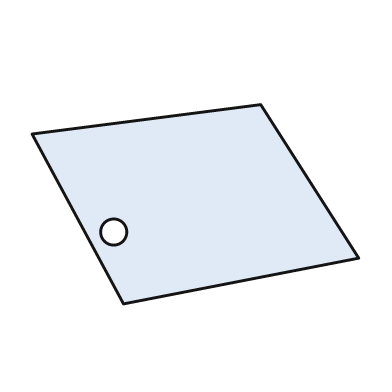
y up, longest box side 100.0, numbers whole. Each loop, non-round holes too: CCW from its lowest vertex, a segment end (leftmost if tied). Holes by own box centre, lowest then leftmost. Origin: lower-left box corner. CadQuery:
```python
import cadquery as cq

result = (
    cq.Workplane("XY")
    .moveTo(28.0, 0.0)
    .lineTo(100.0, 14.0)
    .lineTo(70.0, 61.0)
    .lineTo(0.0, 52.0)
    .close()
    .moveTo(25.0, 22.0)
    .circle(4.0)
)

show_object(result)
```